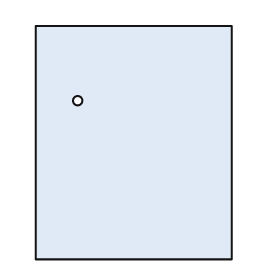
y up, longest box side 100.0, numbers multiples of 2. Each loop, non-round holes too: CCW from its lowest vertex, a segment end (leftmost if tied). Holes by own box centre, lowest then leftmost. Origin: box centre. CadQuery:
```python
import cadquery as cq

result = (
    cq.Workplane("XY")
    .moveTo(-42.0, -50.0)
    .lineTo(42.0, -50.0)
    .lineTo(42.0, 50.0)
    .lineTo(-42.0, 50.0)
    .close()
    .moveTo(-24.0, 18.0)
    .circle(2.0)
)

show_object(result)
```